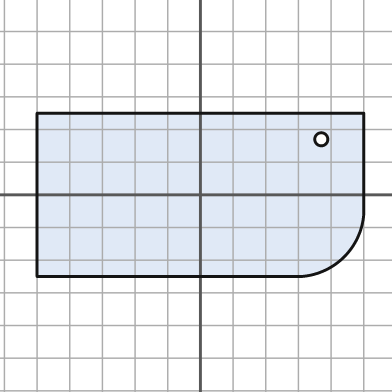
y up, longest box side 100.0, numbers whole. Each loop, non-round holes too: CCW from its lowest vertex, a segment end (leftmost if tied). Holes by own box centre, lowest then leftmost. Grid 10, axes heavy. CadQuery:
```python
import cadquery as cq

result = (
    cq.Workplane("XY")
    .moveTo(-50.0, -25.0)
    .lineTo(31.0, -25.0)
    .threePointArc((44.0, -19.0), (50.0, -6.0))
    .lineTo(50.0, 25.0)
    .lineTo(-50.0, 25.0)
    .close()
    .moveTo(37.0, 17.0)
    .circle(2.0)
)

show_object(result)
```